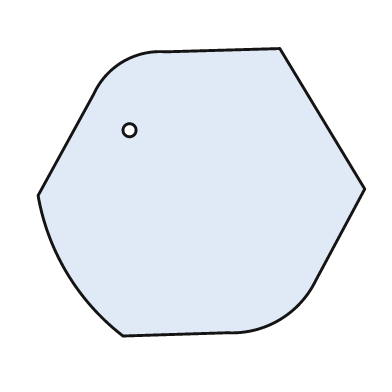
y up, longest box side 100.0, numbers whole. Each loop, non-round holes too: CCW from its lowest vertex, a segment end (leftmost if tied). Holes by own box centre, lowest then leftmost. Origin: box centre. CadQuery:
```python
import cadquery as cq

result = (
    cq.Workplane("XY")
    .moveTo(-24.0, -44.0)
    .lineTo(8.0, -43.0)
    .threePointArc((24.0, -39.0), (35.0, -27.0))
    .lineTo(50.0, 1.0)
    .lineTo(24.0, 44.0)
    .lineTo(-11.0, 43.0)
    .threePointArc((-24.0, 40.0), (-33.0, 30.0))
    .lineTo(-50.0, -1.0)
    .threePointArc((-41.0, -25.0), (-24.0, -44.0))
    .close()
    .moveTo(-22.0, 19.0)
    .circle(2.0)
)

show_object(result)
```